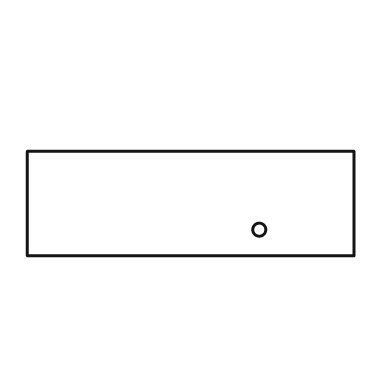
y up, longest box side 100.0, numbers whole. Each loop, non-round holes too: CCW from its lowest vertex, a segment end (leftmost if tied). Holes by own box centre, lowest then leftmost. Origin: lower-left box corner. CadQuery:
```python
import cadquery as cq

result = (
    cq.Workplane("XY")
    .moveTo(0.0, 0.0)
    .lineTo(100.0, 0.0)
    .lineTo(100.0, 32.0)
    .lineTo(0.0, 32.0)
    .close()
    .moveTo(71.0, 8.0)
    .circle(2.0)
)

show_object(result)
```